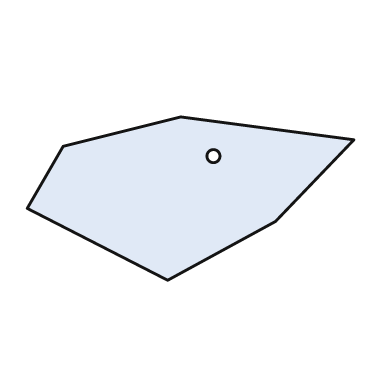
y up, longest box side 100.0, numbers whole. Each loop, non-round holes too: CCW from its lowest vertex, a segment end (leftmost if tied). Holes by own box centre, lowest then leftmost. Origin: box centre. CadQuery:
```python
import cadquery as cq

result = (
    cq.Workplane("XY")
    .moveTo(-7.0, -25.0)
    .lineTo(26.0, -7.0)
    .lineTo(50.0, 18.0)
    .lineTo(-3.0, 25.0)
    .lineTo(-39.0, 16.0)
    .lineTo(-50.0, -3.0)
    .close()
    .moveTo(7.0, 13.0)
    .circle(2.0)
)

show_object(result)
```